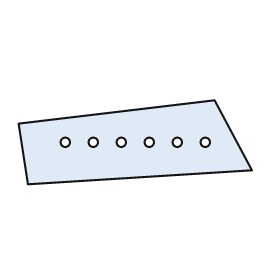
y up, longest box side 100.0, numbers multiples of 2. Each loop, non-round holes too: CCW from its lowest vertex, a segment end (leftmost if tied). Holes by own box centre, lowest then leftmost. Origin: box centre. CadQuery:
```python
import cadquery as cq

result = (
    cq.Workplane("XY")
    .moveTo(-46.0, -18.0)
    .lineTo(50.0, -12.0)
    .lineTo(34.0, 18.0)
    .lineTo(-50.0, 8.0)
    .close()
    .moveTo(-30.0, 0.0)
    .circle(2.0)
    .moveTo(-18.0, 0.0)
    .circle(2.0)
    .moveTo(-6.0, 0.0)
    .circle(2.0)
    .moveTo(6.0, 0.0)
    .circle(2.0)
    .moveTo(18.0, 0.0)
    .circle(2.0)
    .moveTo(30.0, 0.0)
    .circle(2.0)
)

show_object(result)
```